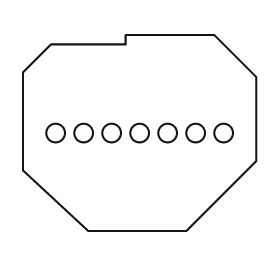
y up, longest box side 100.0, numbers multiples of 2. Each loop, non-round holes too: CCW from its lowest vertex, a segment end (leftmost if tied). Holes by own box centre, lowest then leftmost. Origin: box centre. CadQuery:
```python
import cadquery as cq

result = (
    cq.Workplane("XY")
    .moveTo(-22.0, -42.0)
    .lineTo(20.0, -42.0)
    .lineTo(50.0, -12.0)
    .lineTo(50.0, 24.0)
    .lineTo(32.0, 42.0)
    .lineTo(-6.0, 42.0)
    .lineTo(-6.0, 38.0)
    .lineTo(-38.0, 38.0)
    .lineTo(-50.0, 26.0)
    .lineTo(-50.0, -16.0)
    .close()
    .moveTo(-36.0, 0.0)
    .circle(4.0)
    .moveTo(-24.0, 0.0)
    .circle(4.0)
    .moveTo(-12.0, 0.0)
    .circle(4.0)
    .moveTo(0.0, 0.0)
    .circle(4.0)
    .moveTo(12.0, 0.0)
    .circle(4.0)
    .moveTo(24.0, 0.0)
    .circle(4.0)
    .moveTo(36.0, 0.0)
    .circle(4.0)
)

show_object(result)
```